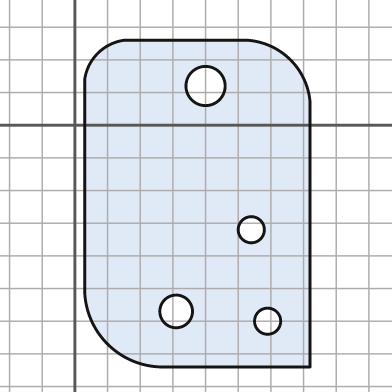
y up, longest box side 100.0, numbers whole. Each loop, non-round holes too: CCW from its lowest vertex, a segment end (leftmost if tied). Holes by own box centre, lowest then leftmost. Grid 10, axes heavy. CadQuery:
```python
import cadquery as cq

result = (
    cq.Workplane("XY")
    .moveTo(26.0, -74.0)
    .lineTo(72.0, -74.0)
    .lineTo(72.0, 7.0)
    .threePointArc((66.0, 20.0), (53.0, 26.0))
    .lineTo(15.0, 26.0)
    .threePointArc((7.0, 22.0), (3.0, 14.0))
    .lineTo(3.0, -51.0)
    .threePointArc((10.0, -67.0), (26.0, -74.0))
    .close()
    .moveTo(59.0, -60.0)
    .circle(4.0)
    .moveTo(31.0, -57.0)
    .circle(5.0)
    .moveTo(54.0, -32.0)
    .circle(4.0)
    .moveTo(40.0, 12.0)
    .circle(6.0)
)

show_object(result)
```